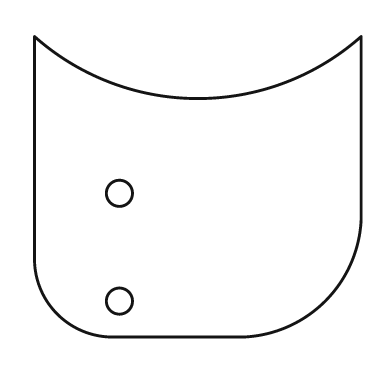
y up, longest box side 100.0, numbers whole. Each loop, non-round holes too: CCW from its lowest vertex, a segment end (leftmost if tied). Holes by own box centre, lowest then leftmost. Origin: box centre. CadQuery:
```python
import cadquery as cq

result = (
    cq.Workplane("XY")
    .moveTo(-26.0, -46.0)
    .lineTo(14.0, -46.0)
    .threePointArc((39.0, -35.0), (50.0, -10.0))
    .lineTo(50.0, 46.0)
    .threePointArc((0.0, 27.0), (-50.0, 46.0))
    .lineTo(-50.0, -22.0)
    .threePointArc((-43.0, -39.0), (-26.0, -46.0))
    .close()
    .moveTo(-24.0, -35.0)
    .circle(4.0)
    .moveTo(-24.0, -2.0)
    .circle(4.0)
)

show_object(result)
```